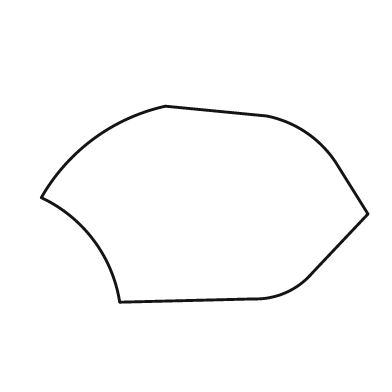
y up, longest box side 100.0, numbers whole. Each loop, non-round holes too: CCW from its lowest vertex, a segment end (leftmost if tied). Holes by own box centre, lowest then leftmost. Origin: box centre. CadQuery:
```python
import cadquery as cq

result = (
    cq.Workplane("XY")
    .moveTo(-26.0, -30.0)
    .lineTo(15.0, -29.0)
    .threePointArc((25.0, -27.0), (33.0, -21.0))
    .lineTo(50.0, -3.0)
    .lineTo(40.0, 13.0)
    .threePointArc((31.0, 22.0), (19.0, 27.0))
    .lineTo(-12.0, 30.0)
    .threePointArc((-34.0, 20.0), (-50.0, 2.0))
    .threePointArc((-34.0, -11.0), (-26.0, -30.0))
    .close()
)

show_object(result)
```